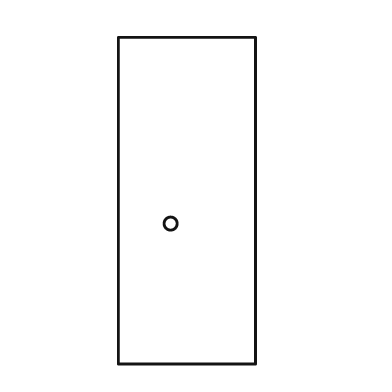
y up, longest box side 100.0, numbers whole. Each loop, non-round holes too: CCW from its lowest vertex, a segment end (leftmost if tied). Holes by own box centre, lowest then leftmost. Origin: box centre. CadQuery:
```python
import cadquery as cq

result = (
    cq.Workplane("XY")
    .moveTo(-21.0, -50.0)
    .lineTo(21.0, -50.0)
    .lineTo(21.0, 50.0)
    .lineTo(-21.0, 50.0)
    .close()
    .moveTo(-5.0, -7.0)
    .circle(2.0)
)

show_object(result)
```